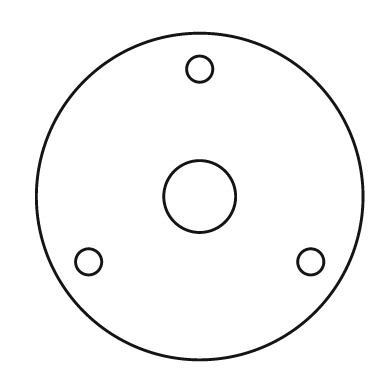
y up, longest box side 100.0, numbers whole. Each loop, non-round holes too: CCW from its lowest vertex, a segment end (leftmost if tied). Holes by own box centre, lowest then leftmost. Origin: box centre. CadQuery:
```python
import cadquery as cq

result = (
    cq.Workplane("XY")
    .moveTo(0.0, 0.0)
    .circle(50.0)
    .moveTo(-34.0, -20.0)
    .circle(4.0)
    .moveTo(34.0, -20.0)
    .circle(4.0)
    .moveTo(0.0, 0.0)
    .circle(11.0)
    .moveTo(0.0, 39.0)
    .circle(4.0)
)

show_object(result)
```